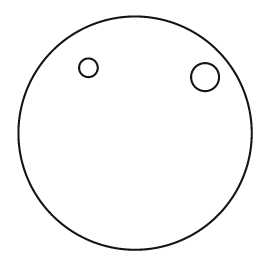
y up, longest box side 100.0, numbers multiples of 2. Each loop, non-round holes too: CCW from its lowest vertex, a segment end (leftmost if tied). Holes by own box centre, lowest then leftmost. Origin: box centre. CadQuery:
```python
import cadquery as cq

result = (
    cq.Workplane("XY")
    .moveTo(0.0, 0.0)
    .circle(50.0)
    .moveTo(30.0, 24.0)
    .circle(6.0)
    .moveTo(-20.0, 28.0)
    .circle(4.0)
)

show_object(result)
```